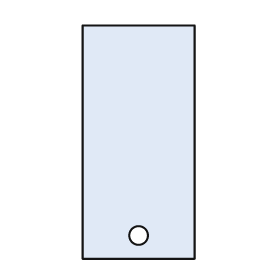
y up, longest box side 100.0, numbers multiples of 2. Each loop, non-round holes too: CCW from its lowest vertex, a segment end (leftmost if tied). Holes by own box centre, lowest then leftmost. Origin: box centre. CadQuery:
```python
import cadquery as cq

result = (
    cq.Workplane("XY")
    .moveTo(-24.0, -50.0)
    .lineTo(24.0, -50.0)
    .lineTo(24.0, 50.0)
    .lineTo(-24.0, 50.0)
    .close()
    .moveTo(0.0, -40.0)
    .circle(4.0)
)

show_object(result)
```